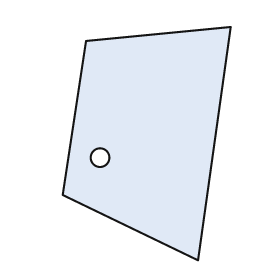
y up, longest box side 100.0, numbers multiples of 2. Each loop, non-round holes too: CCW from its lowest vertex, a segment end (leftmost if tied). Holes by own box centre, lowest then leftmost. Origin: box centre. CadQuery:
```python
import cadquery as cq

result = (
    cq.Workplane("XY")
    .moveTo(22.0, -50.0)
    .lineTo(36.0, 50.0)
    .lineTo(-26.0, 44.0)
    .lineTo(-36.0, -22.0)
    .close()
    .moveTo(-20.0, -6.0)
    .circle(4.0)
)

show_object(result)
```